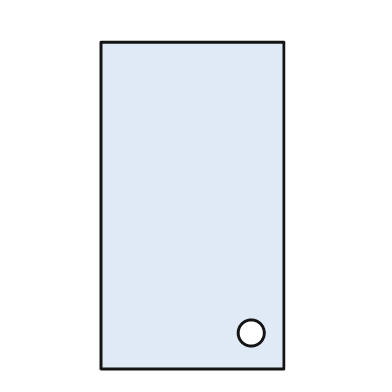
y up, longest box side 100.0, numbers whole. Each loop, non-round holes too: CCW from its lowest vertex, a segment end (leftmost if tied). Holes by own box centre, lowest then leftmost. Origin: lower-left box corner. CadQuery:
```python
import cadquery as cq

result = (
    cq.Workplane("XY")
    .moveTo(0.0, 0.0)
    .lineTo(56.0, 0.0)
    .lineTo(56.0, 100.0)
    .lineTo(0.0, 100.0)
    .close()
    .moveTo(46.0, 11.0)
    .circle(4.0)
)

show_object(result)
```